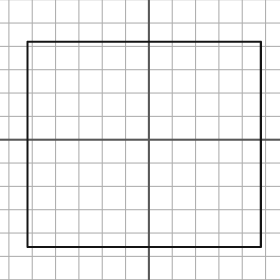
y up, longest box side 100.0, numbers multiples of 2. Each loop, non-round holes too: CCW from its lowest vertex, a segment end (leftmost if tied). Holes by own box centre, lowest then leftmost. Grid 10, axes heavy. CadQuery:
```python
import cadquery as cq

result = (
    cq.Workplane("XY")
    .moveTo(-52.0, -46.0)
    .lineTo(48.0, -46.0)
    .lineTo(48.0, 42.0)
    .lineTo(-52.0, 42.0)
    .close()
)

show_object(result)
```